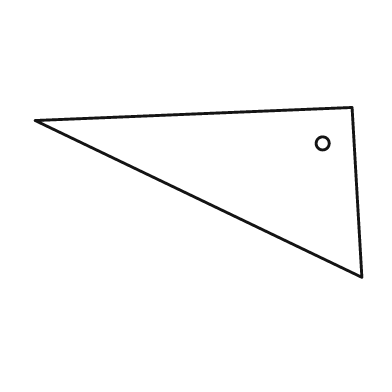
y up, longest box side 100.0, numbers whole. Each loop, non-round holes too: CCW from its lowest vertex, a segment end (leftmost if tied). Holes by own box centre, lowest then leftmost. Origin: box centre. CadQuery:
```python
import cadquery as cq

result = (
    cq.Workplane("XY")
    .moveTo(50.0, -26.0)
    .lineTo(47.0, 26.0)
    .lineTo(-50.0, 22.0)
    .close()
    .moveTo(38.0, 15.0)
    .circle(2.0)
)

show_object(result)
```